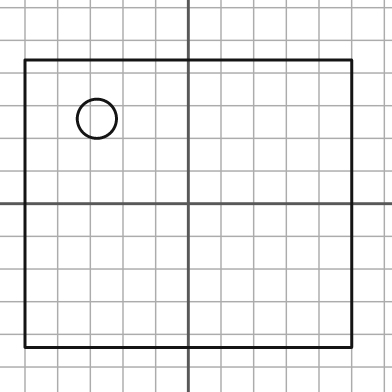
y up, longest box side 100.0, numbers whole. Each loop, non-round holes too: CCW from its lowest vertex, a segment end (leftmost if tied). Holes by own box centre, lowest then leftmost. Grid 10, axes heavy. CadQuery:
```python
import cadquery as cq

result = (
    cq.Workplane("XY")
    .moveTo(-50.0, -44.0)
    .lineTo(50.0, -44.0)
    .lineTo(50.0, 44.0)
    .lineTo(-50.0, 44.0)
    .close()
    .moveTo(-28.0, 26.0)
    .circle(6.0)
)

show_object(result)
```